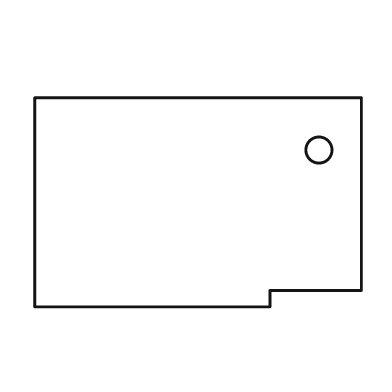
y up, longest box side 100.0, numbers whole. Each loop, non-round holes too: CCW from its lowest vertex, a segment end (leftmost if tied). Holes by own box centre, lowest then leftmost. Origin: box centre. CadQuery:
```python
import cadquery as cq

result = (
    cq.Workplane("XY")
    .moveTo(-50.0, -32.0)
    .lineTo(22.0, -32.0)
    .lineTo(22.0, -27.0)
    .lineTo(50.0, -27.0)
    .lineTo(50.0, 32.0)
    .lineTo(-50.0, 32.0)
    .close()
    .moveTo(37.0, 16.0)
    .circle(4.0)
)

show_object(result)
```